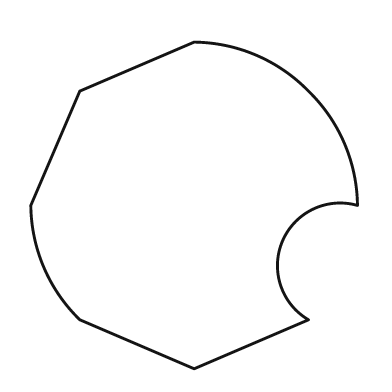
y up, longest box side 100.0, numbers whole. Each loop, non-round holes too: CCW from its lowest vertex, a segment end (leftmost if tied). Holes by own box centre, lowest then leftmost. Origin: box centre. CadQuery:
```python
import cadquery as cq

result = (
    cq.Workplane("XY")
    .moveTo(0.0, -50.0)
    .lineTo(35.0, -35.0)
    .threePointArc((27.0, -11.0), (50.0, 0.0))
    .threePointArc((46.0, 19.0), (35.0, 35.0))
    .threePointArc((19.0, 46.0), (0.0, 50.0))
    .lineTo(-35.0, 35.0)
    .lineTo(-50.0, 0.0)
    .threePointArc((-46.0, -19.0), (-35.0, -35.0))
    .close()
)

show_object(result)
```